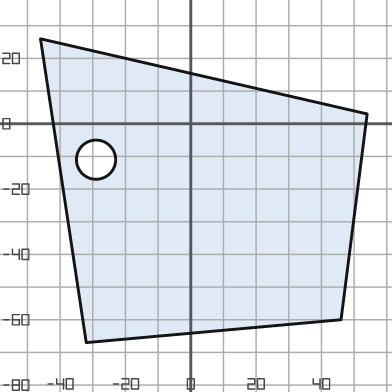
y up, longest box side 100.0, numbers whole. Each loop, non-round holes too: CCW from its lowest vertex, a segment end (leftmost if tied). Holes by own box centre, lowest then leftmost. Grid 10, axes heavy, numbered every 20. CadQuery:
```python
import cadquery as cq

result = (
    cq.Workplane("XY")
    .moveTo(-32.0, -67.0)
    .lineTo(46.0, -60.0)
    .lineTo(54.0, 3.0)
    .lineTo(-46.0, 26.0)
    .close()
    .moveTo(-29.0, -11.0)
    .circle(6.0)
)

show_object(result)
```